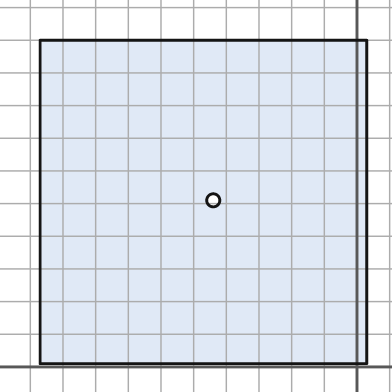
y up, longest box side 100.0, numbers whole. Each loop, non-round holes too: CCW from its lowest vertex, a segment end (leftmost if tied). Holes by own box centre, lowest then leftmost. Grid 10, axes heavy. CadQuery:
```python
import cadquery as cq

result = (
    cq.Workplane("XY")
    .moveTo(-97.0, 1.0)
    .lineTo(3.0, 1.0)
    .lineTo(3.0, 100.0)
    .lineTo(-97.0, 100.0)
    .close()
    .moveTo(-44.0, 51.0)
    .circle(2.0)
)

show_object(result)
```